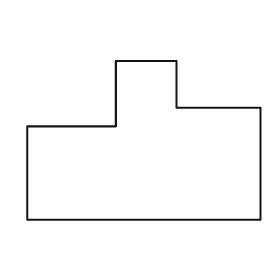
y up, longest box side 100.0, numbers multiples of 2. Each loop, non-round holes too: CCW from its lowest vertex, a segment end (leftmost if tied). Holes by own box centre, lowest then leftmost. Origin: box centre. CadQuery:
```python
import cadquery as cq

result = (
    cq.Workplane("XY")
    .moveTo(-50.0, -34.0)
    .lineTo(50.0, -34.0)
    .lineTo(50.0, 14.0)
    .lineTo(14.0, 14.0)
    .lineTo(14.0, 34.0)
    .lineTo(-12.0, 34.0)
    .lineTo(-12.0, 6.0)
    .lineTo(-50.0, 6.0)
    .close()
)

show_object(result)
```